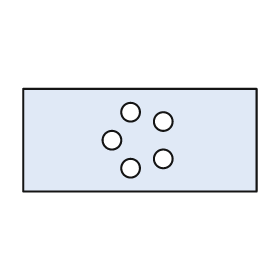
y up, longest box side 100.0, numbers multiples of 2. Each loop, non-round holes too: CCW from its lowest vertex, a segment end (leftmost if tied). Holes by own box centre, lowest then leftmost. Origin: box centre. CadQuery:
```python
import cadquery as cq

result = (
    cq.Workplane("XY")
    .moveTo(-50.0, -22.0)
    .lineTo(50.0, -22.0)
    .lineTo(50.0, 22.0)
    .lineTo(-50.0, 22.0)
    .close()
    .moveTo(-4.0, -12.0)
    .circle(4.0)
    .moveTo(10.0, -8.0)
    .circle(4.0)
    .moveTo(-12.0, 0.0)
    .circle(4.0)
    .moveTo(10.0, 8.0)
    .circle(4.0)
    .moveTo(-4.0, 12.0)
    .circle(4.0)
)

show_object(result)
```